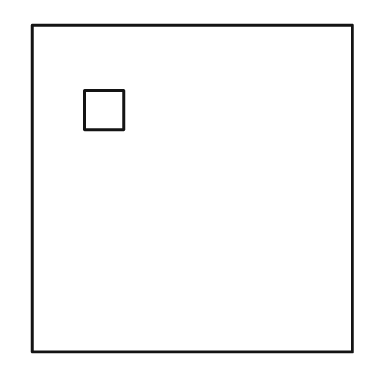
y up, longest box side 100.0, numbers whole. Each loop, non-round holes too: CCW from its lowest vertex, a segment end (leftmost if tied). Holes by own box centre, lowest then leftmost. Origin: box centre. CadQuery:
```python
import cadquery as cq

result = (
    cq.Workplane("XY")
    .moveTo(-49.0, -50.0)
    .lineTo(49.0, -50.0)
    .lineTo(49.0, 50.0)
    .lineTo(-49.0, 50.0)
    .close()
    .moveTo(-33.0, 18.0)
    .lineTo(-21.0, 18.0)
    .lineTo(-21.0, 30.0)
    .lineTo(-33.0, 30.0)
    .close()
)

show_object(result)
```